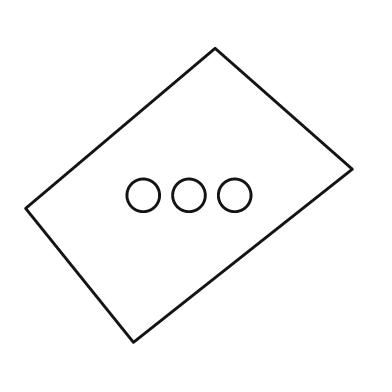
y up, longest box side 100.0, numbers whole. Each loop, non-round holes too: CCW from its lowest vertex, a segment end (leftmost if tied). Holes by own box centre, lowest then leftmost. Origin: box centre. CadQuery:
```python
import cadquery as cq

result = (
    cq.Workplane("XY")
    .moveTo(-17.0, -45.0)
    .lineTo(50.0, 8.0)
    .lineTo(8.0, 45.0)
    .lineTo(-50.0, -4.0)
    .close()
    .moveTo(-14.0, 0.0)
    .circle(5.0)
    .moveTo(0.0, 0.0)
    .circle(5.0)
    .moveTo(14.0, 0.0)
    .circle(5.0)
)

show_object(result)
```